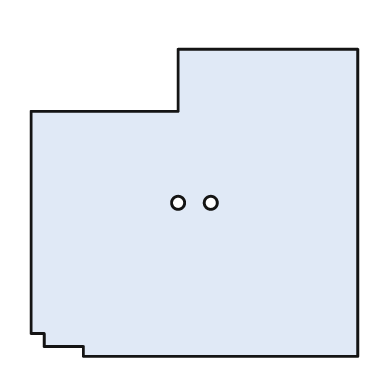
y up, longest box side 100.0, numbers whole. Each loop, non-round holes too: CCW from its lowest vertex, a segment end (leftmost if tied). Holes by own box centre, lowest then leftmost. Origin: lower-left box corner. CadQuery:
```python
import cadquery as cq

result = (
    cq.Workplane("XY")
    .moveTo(16.0, 0.0)
    .lineTo(100.0, 0.0)
    .lineTo(100.0, 94.0)
    .lineTo(45.0, 94.0)
    .lineTo(45.0, 75.0)
    .lineTo(0.0, 75.0)
    .lineTo(0.0, 7.0)
    .lineTo(4.0, 7.0)
    .lineTo(4.0, 3.0)
    .lineTo(16.0, 3.0)
    .close()
    .moveTo(45.0, 47.0)
    .circle(2.0)
    .moveTo(55.0, 47.0)
    .circle(2.0)
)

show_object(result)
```